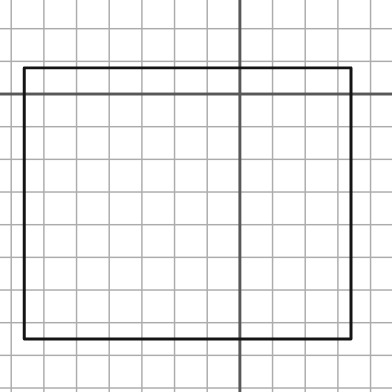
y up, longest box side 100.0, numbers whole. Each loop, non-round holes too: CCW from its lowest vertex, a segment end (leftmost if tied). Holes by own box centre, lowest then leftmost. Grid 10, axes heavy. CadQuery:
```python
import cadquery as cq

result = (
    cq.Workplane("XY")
    .moveTo(-66.0, -75.0)
    .lineTo(34.0, -75.0)
    .lineTo(34.0, 8.0)
    .lineTo(-66.0, 8.0)
    .close()
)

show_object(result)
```